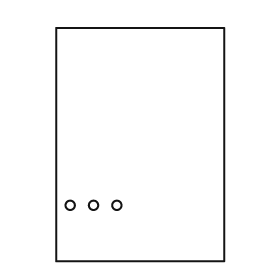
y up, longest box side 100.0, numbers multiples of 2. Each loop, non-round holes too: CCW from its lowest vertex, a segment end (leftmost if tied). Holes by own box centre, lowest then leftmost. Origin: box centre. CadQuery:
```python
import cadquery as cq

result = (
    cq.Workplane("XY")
    .moveTo(-36.0, -50.0)
    .lineTo(36.0, -50.0)
    .lineTo(36.0, 50.0)
    .lineTo(-36.0, 50.0)
    .close()
    .moveTo(-30.0, -26.0)
    .circle(2.0)
    .moveTo(-20.0, -26.0)
    .circle(2.0)
    .moveTo(-10.0, -26.0)
    .circle(2.0)
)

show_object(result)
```